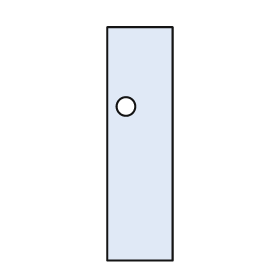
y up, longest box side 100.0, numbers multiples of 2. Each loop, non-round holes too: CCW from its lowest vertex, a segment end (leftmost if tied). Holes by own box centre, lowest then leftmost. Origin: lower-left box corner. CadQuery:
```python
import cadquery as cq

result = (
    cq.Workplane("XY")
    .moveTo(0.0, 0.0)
    .lineTo(28.0, 0.0)
    .lineTo(28.0, 100.0)
    .lineTo(0.0, 100.0)
    .close()
    .moveTo(8.0, 66.0)
    .circle(4.0)
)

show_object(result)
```